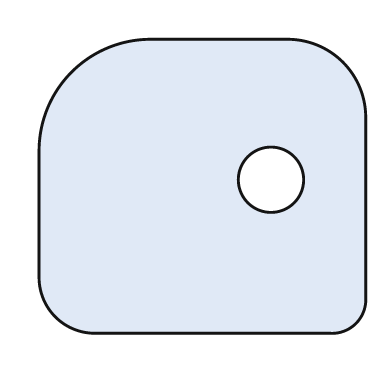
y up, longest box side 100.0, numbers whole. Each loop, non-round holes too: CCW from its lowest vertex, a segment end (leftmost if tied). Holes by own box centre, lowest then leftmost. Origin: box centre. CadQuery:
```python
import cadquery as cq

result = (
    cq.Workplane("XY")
    .moveTo(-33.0, -45.0)
    .lineTo(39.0, -45.0)
    .threePointArc((47.0, -42.0), (50.0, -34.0))
    .lineTo(50.0, 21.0)
    .threePointArc((43.0, 38.0), (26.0, 45.0))
    .lineTo(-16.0, 45.0)
    .threePointArc((-40.0, 35.0), (-50.0, 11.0))
    .lineTo(-50.0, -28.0)
    .threePointArc((-45.0, -40.0), (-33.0, -45.0))
    .close()
    .moveTo(21.0, 2.0)
    .circle(10.0)
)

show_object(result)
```